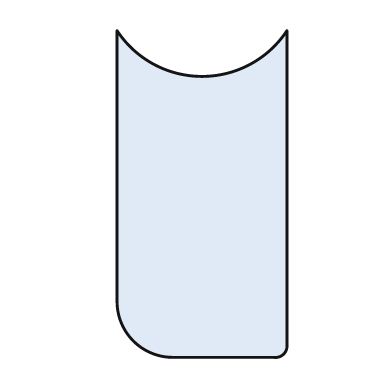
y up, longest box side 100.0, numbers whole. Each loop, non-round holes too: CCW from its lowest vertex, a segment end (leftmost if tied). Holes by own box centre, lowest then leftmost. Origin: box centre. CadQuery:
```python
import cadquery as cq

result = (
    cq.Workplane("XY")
    .moveTo(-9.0, -50.0)
    .lineTo(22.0, -50.0)
    .threePointArc((25.0, -49.0), (26.0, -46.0))
    .lineTo(26.0, 50.0)
    .threePointArc((0.0, 36.0), (-26.0, 50.0))
    .lineTo(-26.0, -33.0)
    .threePointArc((-21.0, -45.0), (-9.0, -50.0))
    .close()
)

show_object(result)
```